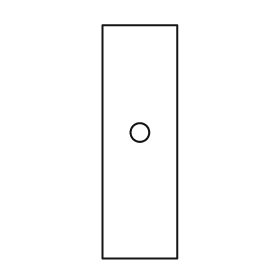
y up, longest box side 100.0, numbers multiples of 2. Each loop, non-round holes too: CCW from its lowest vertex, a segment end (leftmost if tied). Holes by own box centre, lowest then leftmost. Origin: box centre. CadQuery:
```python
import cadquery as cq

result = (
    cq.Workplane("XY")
    .moveTo(-16.0, -50.0)
    .lineTo(16.0, -50.0)
    .lineTo(16.0, 50.0)
    .lineTo(-16.0, 50.0)
    .close()
    .moveTo(0.0, 4.0)
    .circle(4.0)
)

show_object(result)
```